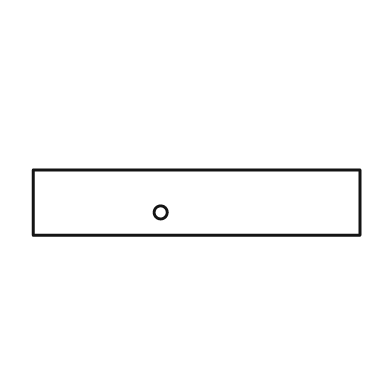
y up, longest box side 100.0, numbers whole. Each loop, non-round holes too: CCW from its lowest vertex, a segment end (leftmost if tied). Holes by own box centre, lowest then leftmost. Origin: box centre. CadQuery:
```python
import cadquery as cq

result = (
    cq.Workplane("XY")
    .moveTo(-50.0, -10.0)
    .lineTo(50.0, -10.0)
    .lineTo(50.0, 10.0)
    .lineTo(-50.0, 10.0)
    .close()
    .moveTo(-11.0, -3.0)
    .circle(2.0)
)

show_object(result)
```